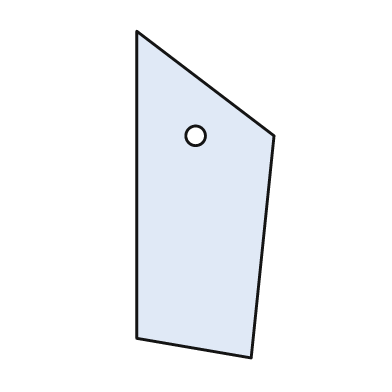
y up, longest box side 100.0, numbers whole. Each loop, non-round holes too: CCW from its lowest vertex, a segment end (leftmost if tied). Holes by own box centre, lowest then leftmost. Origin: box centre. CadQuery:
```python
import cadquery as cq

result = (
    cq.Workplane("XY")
    .moveTo(14.0, -50.0)
    .lineTo(21.0, 18.0)
    .lineTo(-21.0, 50.0)
    .lineTo(-21.0, -44.0)
    .close()
    .moveTo(-3.0, 18.0)
    .circle(3.0)
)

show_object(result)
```